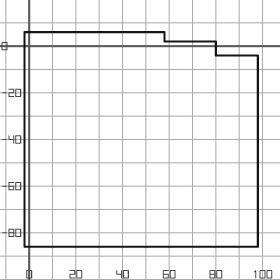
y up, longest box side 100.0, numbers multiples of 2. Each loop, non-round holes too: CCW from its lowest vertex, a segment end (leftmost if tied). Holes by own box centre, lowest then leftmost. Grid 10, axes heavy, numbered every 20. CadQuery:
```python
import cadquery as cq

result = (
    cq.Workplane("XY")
    .moveTo(-2.0, -86.0)
    .lineTo(98.0, -86.0)
    .lineTo(98.0, -4.0)
    .lineTo(80.0, -4.0)
    .lineTo(80.0, 2.0)
    .lineTo(58.0, 2.0)
    .lineTo(58.0, 6.0)
    .lineTo(-2.0, 6.0)
    .close()
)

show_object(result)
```